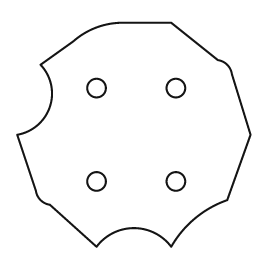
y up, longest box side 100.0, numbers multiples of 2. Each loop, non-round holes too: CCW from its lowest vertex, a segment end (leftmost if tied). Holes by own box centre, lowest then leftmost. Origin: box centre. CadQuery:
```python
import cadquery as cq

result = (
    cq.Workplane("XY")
    .moveTo(-16.0, -48.0)
    .threePointArc((0.0, -40.0), (16.0, -48.0))
    .threePointArc((26.0, -36.0), (40.0, -28.0))
    .lineTo(50.0, 0.0)
    .lineTo(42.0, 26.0)
    .threePointArc((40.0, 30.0), (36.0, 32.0))
    .lineTo(16.0, 48.0)
    .lineTo(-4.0, 48.0)
    .threePointArc((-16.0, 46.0), (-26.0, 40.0))
    .lineTo(-40.0, 30.0)
    .threePointArc((-36.0, 12.0), (-50.0, 0.0))
    .lineTo(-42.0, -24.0)
    .threePointArc((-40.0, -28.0), (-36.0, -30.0))
    .close()
    .moveTo(-16.0, -20.0)
    .circle(4.0)
    .moveTo(18.0, -20.0)
    .circle(4.0)
    .moveTo(-16.0, 20.0)
    .circle(4.0)
    .moveTo(18.0, 20.0)
    .circle(4.0)
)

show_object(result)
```